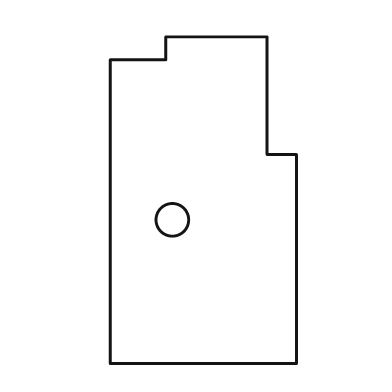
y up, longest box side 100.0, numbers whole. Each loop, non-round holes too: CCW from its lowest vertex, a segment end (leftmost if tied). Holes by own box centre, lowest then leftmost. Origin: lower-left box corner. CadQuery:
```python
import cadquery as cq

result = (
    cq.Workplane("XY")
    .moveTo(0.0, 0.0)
    .lineTo(57.0, 0.0)
    .lineTo(57.0, 64.0)
    .lineTo(48.0, 64.0)
    .lineTo(48.0, 100.0)
    .lineTo(17.0, 100.0)
    .lineTo(17.0, 93.0)
    .lineTo(0.0, 93.0)
    .close()
    .moveTo(19.0, 44.0)
    .circle(5.0)
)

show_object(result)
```